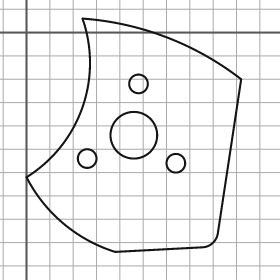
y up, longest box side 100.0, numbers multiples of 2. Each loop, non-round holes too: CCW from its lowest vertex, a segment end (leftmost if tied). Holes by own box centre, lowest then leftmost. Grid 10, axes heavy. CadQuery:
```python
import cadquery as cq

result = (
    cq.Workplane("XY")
    .moveTo(38.0, -94.0)
    .lineTo(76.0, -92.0)
    .threePointArc((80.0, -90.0), (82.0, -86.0))
    .lineTo(92.0, -20.0)
    .threePointArc((60.0, -2.0), (24.0, 6.0))
    .threePointArc((24.0, -32.0), (0.0, -62.0))
    .threePointArc((16.0, -82.0), (38.0, -94.0))
    .close()
    .moveTo(64.0, -56.0)
    .circle(4.0)
    .moveTo(26.0, -54.0)
    .circle(4.0)
    .moveTo(46.0, -44.0)
    .circle(10.0)
    .moveTo(48.0, -22.0)
    .circle(4.0)
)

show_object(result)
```